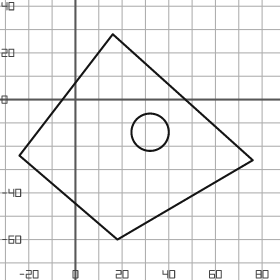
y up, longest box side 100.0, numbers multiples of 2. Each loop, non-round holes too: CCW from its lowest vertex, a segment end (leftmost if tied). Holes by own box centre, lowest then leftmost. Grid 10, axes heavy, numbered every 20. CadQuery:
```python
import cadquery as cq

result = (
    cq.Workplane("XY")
    .moveTo(18.0, -60.0)
    .lineTo(76.0, -26.0)
    .lineTo(16.0, 28.0)
    .lineTo(-24.0, -24.0)
    .close()
    .moveTo(32.0, -14.0)
    .circle(8.0)
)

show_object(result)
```